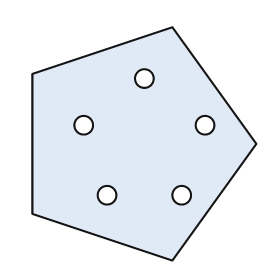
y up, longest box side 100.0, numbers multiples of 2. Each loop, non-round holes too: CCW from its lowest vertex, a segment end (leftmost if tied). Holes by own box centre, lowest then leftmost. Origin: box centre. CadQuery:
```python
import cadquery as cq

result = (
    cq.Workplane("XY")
    .moveTo(12.0, -50.0)
    .lineTo(48.0, 0.0)
    .lineTo(12.0, 50.0)
    .lineTo(-48.0, 30.0)
    .lineTo(-48.0, -30.0)
    .close()
    .moveTo(-16.0, -22.0)
    .circle(4.0)
    .moveTo(16.0, -22.0)
    .circle(4.0)
    .moveTo(-26.0, 8.0)
    .circle(4.0)
    .moveTo(26.0, 8.0)
    .circle(4.0)
    .moveTo(0.0, 28.0)
    .circle(4.0)
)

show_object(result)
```